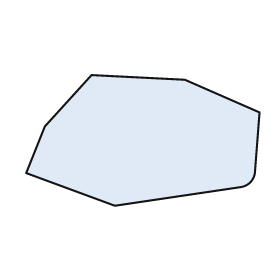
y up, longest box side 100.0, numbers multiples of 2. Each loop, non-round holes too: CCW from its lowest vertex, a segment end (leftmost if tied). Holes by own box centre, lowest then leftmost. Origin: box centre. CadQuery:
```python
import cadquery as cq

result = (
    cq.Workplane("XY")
    .moveTo(-12.0, -28.0)
    .lineTo(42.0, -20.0)
    .threePointArc((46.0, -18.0), (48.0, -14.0))
    .lineTo(50.0, 12.0)
    .lineTo(18.0, 26.0)
    .lineTo(-22.0, 28.0)
    .lineTo(-42.0, 6.0)
    .lineTo(-50.0, -14.0)
    .close()
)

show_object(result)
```